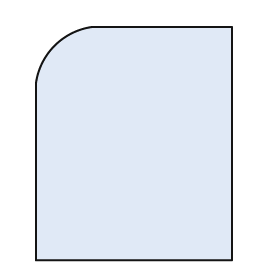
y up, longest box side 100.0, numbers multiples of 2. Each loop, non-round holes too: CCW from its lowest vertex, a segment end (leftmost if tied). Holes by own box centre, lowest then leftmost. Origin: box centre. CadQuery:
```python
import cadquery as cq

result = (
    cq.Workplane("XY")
    .moveTo(-42.0, -50.0)
    .lineTo(42.0, -50.0)
    .lineTo(42.0, 50.0)
    .lineTo(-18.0, 50.0)
    .threePointArc((-34.0, 42.0), (-42.0, 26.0))
    .close()
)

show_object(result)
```